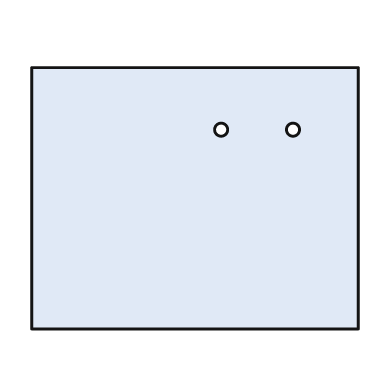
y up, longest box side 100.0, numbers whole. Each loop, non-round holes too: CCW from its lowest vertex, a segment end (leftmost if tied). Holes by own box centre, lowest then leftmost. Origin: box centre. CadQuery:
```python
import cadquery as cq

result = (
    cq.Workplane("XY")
    .moveTo(-50.0, -40.0)
    .lineTo(50.0, -40.0)
    .lineTo(50.0, 40.0)
    .lineTo(-50.0, 40.0)
    .close()
    .moveTo(8.0, 21.0)
    .circle(2.0)
    .moveTo(30.0, 21.0)
    .circle(2.0)
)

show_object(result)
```